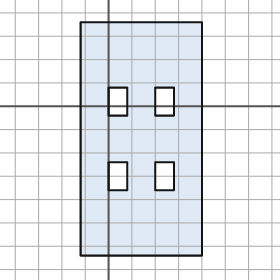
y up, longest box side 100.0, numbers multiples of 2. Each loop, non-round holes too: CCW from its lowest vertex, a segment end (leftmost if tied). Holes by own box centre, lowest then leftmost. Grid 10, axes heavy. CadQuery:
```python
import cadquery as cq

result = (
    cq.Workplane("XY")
    .moveTo(-12.0, -64.0)
    .lineTo(40.0, -64.0)
    .lineTo(40.0, 36.0)
    .lineTo(-12.0, 36.0)
    .close()
    .moveTo(0.0, -36.0)
    .lineTo(8.0, -36.0)
    .lineTo(8.0, -24.0)
    .lineTo(0.0, -24.0)
    .close()
    .moveTo(20.0, -36.0)
    .lineTo(28.0, -36.0)
    .lineTo(28.0, -24.0)
    .lineTo(20.0, -24.0)
    .close()
    .moveTo(0.0, -4.0)
    .lineTo(8.0, -4.0)
    .lineTo(8.0, 8.0)
    .lineTo(0.0, 8.0)
    .close()
    .moveTo(20.0, -4.0)
    .lineTo(28.0, -4.0)
    .lineTo(28.0, 8.0)
    .lineTo(20.0, 8.0)
    .close()
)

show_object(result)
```